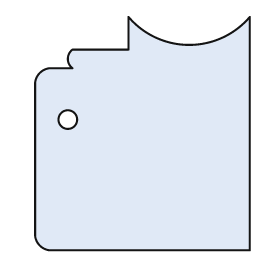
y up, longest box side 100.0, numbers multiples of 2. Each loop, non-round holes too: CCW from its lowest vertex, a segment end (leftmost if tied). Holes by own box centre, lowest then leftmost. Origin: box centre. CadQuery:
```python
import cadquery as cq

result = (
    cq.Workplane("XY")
    .moveTo(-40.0, -50.0)
    .lineTo(46.0, -50.0)
    .lineTo(46.0, 50.0)
    .threePointArc((20.0, 38.0), (-6.0, 50.0))
    .lineTo(-6.0, 36.0)
    .lineTo(-30.0, 36.0)
    .threePointArc((-32.0, 32.0), (-30.0, 28.0))
    .lineTo(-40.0, 28.0)
    .threePointArc((-44.0, 26.0), (-46.0, 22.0))
    .lineTo(-46.0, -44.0)
    .threePointArc((-44.0, -48.0), (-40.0, -50.0))
    .close()
    .moveTo(-32.0, 6.0)
    .circle(4.0)
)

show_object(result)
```